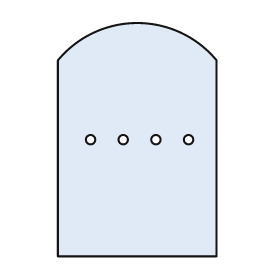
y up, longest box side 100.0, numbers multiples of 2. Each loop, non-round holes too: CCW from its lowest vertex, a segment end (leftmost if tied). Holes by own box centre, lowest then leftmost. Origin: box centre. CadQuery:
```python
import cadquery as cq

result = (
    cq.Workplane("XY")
    .moveTo(-34.0, -50.0)
    .lineTo(34.0, -50.0)
    .lineTo(34.0, 34.0)
    .threePointArc((0.0, 50.0), (-34.0, 34.0))
    .close()
    .moveTo(-20.0, 0.0)
    .circle(2.0)
    .moveTo(-6.0, 0.0)
    .circle(2.0)
    .moveTo(8.0, 0.0)
    .circle(2.0)
    .moveTo(22.0, 0.0)
    .circle(2.0)
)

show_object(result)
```